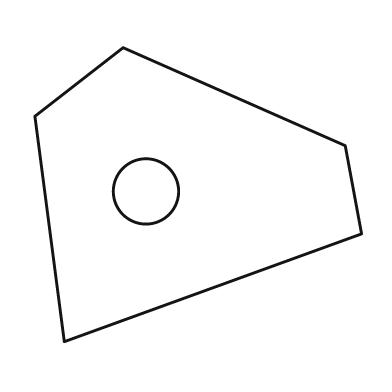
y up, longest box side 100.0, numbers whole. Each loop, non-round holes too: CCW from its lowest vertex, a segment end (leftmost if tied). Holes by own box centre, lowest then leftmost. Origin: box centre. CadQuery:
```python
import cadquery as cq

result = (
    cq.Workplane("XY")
    .moveTo(-41.0, -45.0)
    .lineTo(50.0, -12.0)
    .lineTo(45.0, 15.0)
    .lineTo(-23.0, 45.0)
    .lineTo(-50.0, 24.0)
    .close()
    .moveTo(-16.0, 1.0)
    .circle(10.0)
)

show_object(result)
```